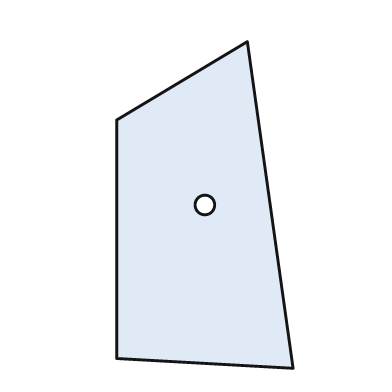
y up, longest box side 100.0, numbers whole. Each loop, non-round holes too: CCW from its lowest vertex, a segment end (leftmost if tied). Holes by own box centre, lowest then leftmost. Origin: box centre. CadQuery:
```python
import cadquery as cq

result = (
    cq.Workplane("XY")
    .moveTo(27.0, -50.0)
    .lineTo(13.0, 50.0)
    .lineTo(-27.0, 26.0)
    .lineTo(-27.0, -47.0)
    .close()
    .moveTo(0.0, 0.0)
    .circle(3.0)
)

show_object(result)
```